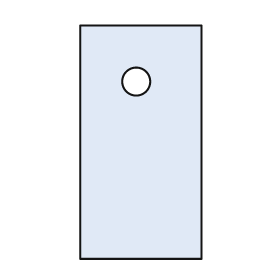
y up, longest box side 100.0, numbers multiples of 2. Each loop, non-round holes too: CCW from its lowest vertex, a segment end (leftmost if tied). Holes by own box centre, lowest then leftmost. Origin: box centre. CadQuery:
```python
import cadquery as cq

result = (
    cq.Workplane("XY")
    .moveTo(-26.0, -50.0)
    .lineTo(26.0, -50.0)
    .lineTo(26.0, 50.0)
    .lineTo(-26.0, 50.0)
    .close()
    .moveTo(-2.0, 26.0)
    .circle(6.0)
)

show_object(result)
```